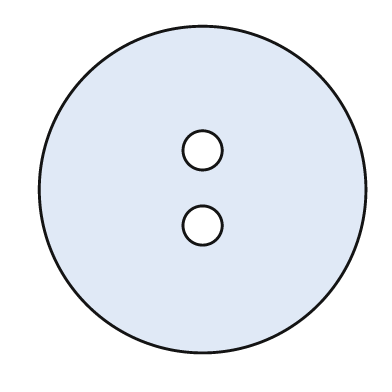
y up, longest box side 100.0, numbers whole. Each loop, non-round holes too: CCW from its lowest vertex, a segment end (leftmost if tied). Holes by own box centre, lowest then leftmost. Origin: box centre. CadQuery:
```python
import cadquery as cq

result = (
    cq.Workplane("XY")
    .moveTo(0.0, 0.0)
    .circle(50.0)
    .moveTo(0.0, -11.0)
    .circle(6.0)
    .moveTo(0.0, 12.0)
    .circle(6.0)
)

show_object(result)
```